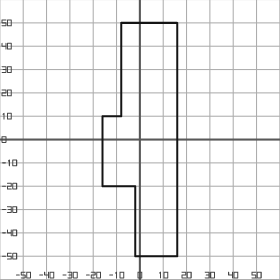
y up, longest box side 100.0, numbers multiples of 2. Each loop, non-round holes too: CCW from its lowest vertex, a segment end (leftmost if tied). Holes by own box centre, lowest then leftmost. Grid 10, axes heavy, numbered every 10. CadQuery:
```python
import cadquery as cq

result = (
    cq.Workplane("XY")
    .moveTo(-2.0, -50.0)
    .lineTo(16.0, -50.0)
    .lineTo(16.0, 50.0)
    .lineTo(-8.0, 50.0)
    .lineTo(-8.0, 10.0)
    .lineTo(-16.0, 10.0)
    .lineTo(-16.0, -20.0)
    .lineTo(-2.0, -20.0)
    .close()
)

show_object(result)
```